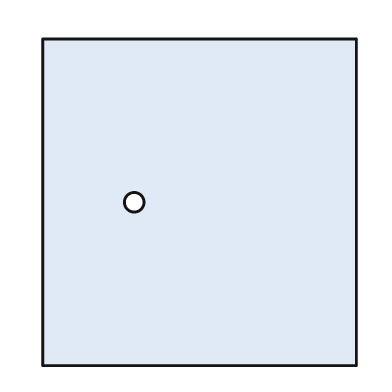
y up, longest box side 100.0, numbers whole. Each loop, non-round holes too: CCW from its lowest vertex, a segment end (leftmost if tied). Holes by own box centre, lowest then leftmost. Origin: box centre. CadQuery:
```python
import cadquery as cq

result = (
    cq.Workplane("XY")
    .moveTo(-48.0, -50.0)
    .lineTo(48.0, -50.0)
    .lineTo(48.0, 50.0)
    .lineTo(-48.0, 50.0)
    .close()
    .moveTo(-20.0, 0.0)
    .circle(3.0)
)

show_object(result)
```